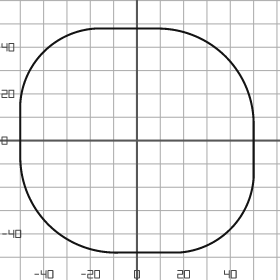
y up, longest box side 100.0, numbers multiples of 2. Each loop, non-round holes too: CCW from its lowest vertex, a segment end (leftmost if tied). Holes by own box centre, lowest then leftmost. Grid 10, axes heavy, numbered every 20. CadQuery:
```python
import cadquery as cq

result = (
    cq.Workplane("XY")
    .moveTo(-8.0, -48.0)
    .lineTo(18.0, -48.0)
    .threePointArc((40.0, -38.0), (50.0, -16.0))
    .lineTo(50.0, 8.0)
    .threePointArc((38.0, 36.0), (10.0, 48.0))
    .lineTo(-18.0, 48.0)
    .threePointArc((-40.0, 38.0), (-50.0, 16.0))
    .lineTo(-50.0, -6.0)
    .threePointArc((-38.0, -36.0), (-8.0, -48.0))
    .close()
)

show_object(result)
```